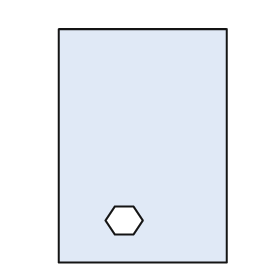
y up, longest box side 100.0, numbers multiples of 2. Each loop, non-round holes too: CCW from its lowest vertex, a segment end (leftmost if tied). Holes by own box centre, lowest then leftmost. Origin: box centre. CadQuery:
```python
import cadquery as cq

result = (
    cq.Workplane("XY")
    .moveTo(-36.0, -50.0)
    .lineTo(36.0, -50.0)
    .lineTo(36.0, 50.0)
    .lineTo(-36.0, 50.0)
    .close()
    .moveTo(-12.0, -38.0)
    .lineTo(-4.0, -38.0)
    .lineTo(0.0, -32.0)
    .lineTo(-4.0, -26.0)
    .lineTo(-12.0, -26.0)
    .lineTo(-16.0, -32.0)
    .close()
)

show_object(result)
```